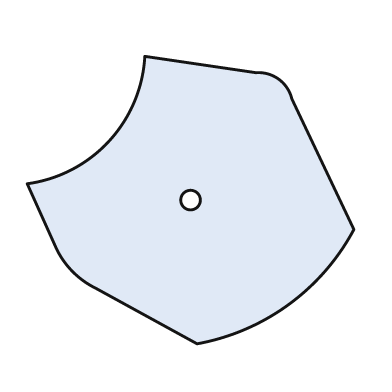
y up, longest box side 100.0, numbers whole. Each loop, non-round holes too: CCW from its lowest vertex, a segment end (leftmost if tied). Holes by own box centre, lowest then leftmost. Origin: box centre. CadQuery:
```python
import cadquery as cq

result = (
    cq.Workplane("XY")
    .moveTo(2.0, -44.0)
    .threePointArc((30.0, -32.0), (50.0, -9.0))
    .lineTo(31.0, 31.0)
    .threePointArc((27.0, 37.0), (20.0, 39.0))
    .lineTo(-14.0, 44.0)
    .threePointArc((-25.0, 18.0), (-50.0, 5.0))
    .lineTo(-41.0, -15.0)
    .threePointArc((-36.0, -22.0), (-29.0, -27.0))
    .close()
    .moveTo(0.0, 0.0)
    .circle(3.0)
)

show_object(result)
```